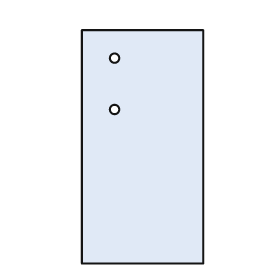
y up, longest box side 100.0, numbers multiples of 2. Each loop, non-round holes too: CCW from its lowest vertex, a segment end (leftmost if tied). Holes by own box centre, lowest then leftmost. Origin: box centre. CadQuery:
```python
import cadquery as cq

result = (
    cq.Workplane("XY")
    .moveTo(-26.0, -50.0)
    .lineTo(26.0, -50.0)
    .lineTo(26.0, 50.0)
    .lineTo(-26.0, 50.0)
    .close()
    .moveTo(-12.0, 16.0)
    .circle(2.0)
    .moveTo(-12.0, 38.0)
    .circle(2.0)
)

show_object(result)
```